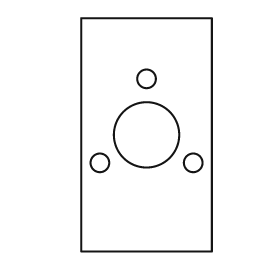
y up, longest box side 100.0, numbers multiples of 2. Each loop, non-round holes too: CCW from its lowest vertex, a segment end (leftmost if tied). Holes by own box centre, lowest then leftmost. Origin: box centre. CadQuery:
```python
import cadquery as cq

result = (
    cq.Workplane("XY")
    .moveTo(-28.0, -50.0)
    .lineTo(28.0, -50.0)
    .lineTo(28.0, 50.0)
    .lineTo(-28.0, 50.0)
    .close()
    .moveTo(-20.0, -12.0)
    .circle(4.0)
    .moveTo(20.0, -12.0)
    .circle(4.0)
    .moveTo(0.0, 0.0)
    .circle(14.0)
    .moveTo(0.0, 24.0)
    .circle(4.0)
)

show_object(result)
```